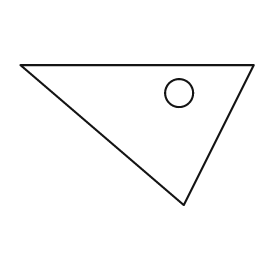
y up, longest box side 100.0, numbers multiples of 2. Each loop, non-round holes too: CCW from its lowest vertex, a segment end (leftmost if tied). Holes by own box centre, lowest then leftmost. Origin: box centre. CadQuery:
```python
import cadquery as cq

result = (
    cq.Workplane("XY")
    .moveTo(20.0, -30.0)
    .lineTo(50.0, 30.0)
    .lineTo(-50.0, 30.0)
    .close()
    .moveTo(18.0, 18.0)
    .circle(6.0)
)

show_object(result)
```